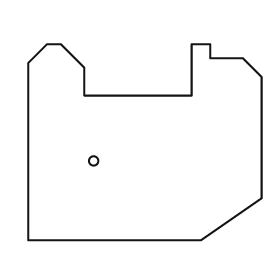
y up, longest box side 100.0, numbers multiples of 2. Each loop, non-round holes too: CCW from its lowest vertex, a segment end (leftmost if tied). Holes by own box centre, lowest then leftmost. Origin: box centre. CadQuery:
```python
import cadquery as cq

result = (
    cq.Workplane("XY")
    .moveTo(-50.0, -42.0)
    .lineTo(24.0, -42.0)
    .lineTo(50.0, -24.0)
    .lineTo(50.0, 28.0)
    .lineTo(42.0, 36.0)
    .lineTo(28.0, 36.0)
    .lineTo(28.0, 42.0)
    .lineTo(20.0, 42.0)
    .lineTo(20.0, 20.0)
    .lineTo(-26.0, 20.0)
    .lineTo(-26.0, 32.0)
    .lineTo(-36.0, 42.0)
    .lineTo(-42.0, 42.0)
    .lineTo(-50.0, 34.0)
    .close()
    .moveTo(-22.0, -8.0)
    .circle(2.0)
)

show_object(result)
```